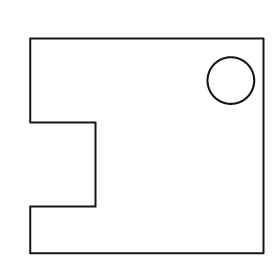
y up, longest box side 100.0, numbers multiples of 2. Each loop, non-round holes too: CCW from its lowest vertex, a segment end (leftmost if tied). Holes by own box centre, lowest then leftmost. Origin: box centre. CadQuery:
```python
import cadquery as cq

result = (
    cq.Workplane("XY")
    .moveTo(-50.0, -46.0)
    .lineTo(50.0, -46.0)
    .lineTo(50.0, 46.0)
    .lineTo(-50.0, 46.0)
    .lineTo(-50.0, 10.0)
    .lineTo(-22.0, 10.0)
    .lineTo(-22.0, -26.0)
    .lineTo(-50.0, -26.0)
    .close()
    .moveTo(36.0, 28.0)
    .circle(10.0)
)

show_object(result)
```